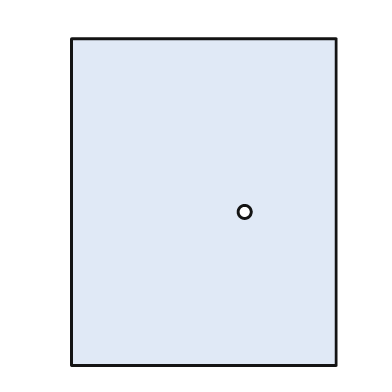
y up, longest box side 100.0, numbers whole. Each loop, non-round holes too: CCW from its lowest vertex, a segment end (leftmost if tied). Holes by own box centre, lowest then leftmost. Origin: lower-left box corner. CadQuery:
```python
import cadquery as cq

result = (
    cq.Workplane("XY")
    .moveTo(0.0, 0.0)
    .lineTo(81.0, 0.0)
    .lineTo(81.0, 100.0)
    .lineTo(0.0, 100.0)
    .close()
    .moveTo(53.0, 47.0)
    .circle(2.0)
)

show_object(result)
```